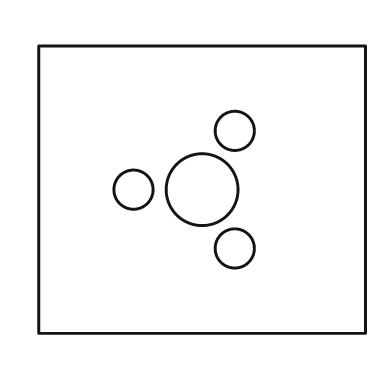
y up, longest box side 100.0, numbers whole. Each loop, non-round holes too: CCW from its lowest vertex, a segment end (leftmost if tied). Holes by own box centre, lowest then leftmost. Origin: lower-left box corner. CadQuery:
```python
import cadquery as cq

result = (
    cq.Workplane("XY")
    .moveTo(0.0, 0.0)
    .lineTo(100.0, 0.0)
    .lineTo(100.0, 88.0)
    .lineTo(0.0, 88.0)
    .close()
    .moveTo(60.0, 26.0)
    .circle(6.0)
    .moveTo(29.0, 44.0)
    .circle(6.0)
    .moveTo(50.0, 44.0)
    .circle(11.0)
    .moveTo(60.0, 62.0)
    .circle(6.0)
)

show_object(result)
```